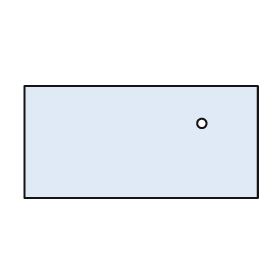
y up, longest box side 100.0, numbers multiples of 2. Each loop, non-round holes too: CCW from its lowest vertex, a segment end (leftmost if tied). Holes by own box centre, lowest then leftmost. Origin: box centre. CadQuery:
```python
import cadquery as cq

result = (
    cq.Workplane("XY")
    .moveTo(-50.0, -24.0)
    .lineTo(50.0, -24.0)
    .lineTo(50.0, 24.0)
    .lineTo(-50.0, 24.0)
    .close()
    .moveTo(26.0, 8.0)
    .circle(2.0)
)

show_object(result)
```